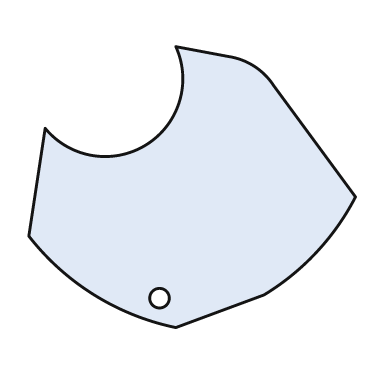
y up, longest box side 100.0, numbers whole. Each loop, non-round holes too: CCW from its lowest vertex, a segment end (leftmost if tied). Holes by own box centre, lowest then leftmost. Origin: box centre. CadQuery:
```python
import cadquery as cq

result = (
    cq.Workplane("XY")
    .moveTo(-5.0, -43.0)
    .lineTo(22.0, -33.0)
    .threePointArc((38.0, -20.0), (50.0, -3.0))
    .lineTo(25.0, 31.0)
    .threePointArc((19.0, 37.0), (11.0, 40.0))
    .lineTo(-5.0, 43.0)
    .threePointArc((-14.0, 13.0), (-45.0, 18.0))
    .lineTo(-50.0, -15.0)
    .threePointArc((-30.0, -33.0), (-5.0, -43.0))
    .close()
    .moveTo(-10.0, -34.0)
    .circle(3.0)
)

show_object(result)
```